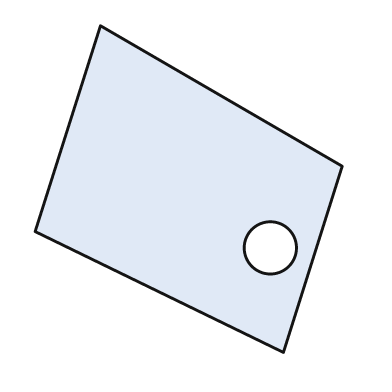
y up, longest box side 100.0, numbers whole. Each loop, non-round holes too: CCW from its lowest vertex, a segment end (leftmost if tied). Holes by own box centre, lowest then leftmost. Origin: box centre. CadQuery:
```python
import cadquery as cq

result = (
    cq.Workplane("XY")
    .moveTo(29.0, -50.0)
    .lineTo(47.0, 7.0)
    .lineTo(-27.0, 50.0)
    .lineTo(-47.0, -13.0)
    .close()
    .moveTo(25.0, -18.0)
    .circle(8.0)
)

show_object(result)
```